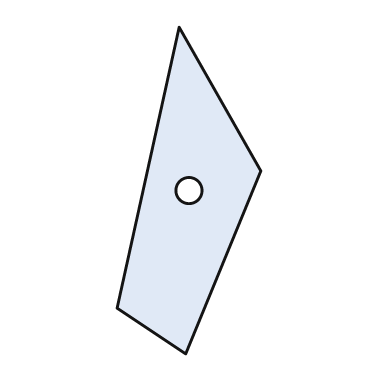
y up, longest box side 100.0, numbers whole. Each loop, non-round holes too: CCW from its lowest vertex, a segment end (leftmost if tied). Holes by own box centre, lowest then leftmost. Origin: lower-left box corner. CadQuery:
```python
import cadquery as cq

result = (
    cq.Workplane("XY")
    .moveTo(21.0, 0.0)
    .lineTo(44.0, 56.0)
    .lineTo(19.0, 100.0)
    .lineTo(0.0, 14.0)
    .close()
    .moveTo(22.0, 50.0)
    .circle(4.0)
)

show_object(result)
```